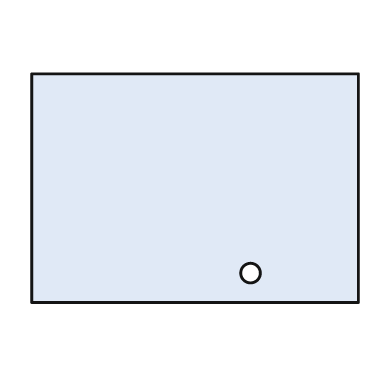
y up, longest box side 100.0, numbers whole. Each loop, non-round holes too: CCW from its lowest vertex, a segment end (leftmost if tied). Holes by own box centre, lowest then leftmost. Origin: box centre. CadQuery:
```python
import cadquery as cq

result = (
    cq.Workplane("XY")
    .moveTo(-50.0, -35.0)
    .lineTo(50.0, -35.0)
    .lineTo(50.0, 35.0)
    .lineTo(-50.0, 35.0)
    .close()
    .moveTo(17.0, -26.0)
    .circle(3.0)
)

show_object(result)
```